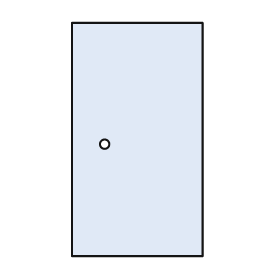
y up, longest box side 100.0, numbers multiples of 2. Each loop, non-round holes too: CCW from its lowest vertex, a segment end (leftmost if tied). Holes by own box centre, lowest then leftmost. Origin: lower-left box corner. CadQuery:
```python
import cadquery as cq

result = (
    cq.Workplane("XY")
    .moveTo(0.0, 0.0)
    .lineTo(56.0, 0.0)
    .lineTo(56.0, 100.0)
    .lineTo(0.0, 100.0)
    .close()
    .moveTo(14.0, 48.0)
    .circle(2.0)
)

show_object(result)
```